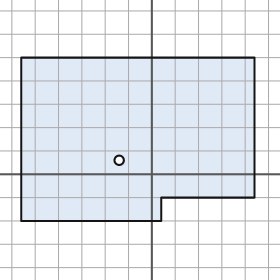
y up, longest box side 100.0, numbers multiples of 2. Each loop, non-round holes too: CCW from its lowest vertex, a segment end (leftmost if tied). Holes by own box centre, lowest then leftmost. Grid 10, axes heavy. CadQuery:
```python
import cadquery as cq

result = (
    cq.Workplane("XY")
    .moveTo(-56.0, -20.0)
    .lineTo(4.0, -20.0)
    .lineTo(4.0, -10.0)
    .lineTo(44.0, -10.0)
    .lineTo(44.0, 50.0)
    .lineTo(-56.0, 50.0)
    .close()
    .moveTo(-14.0, 6.0)
    .circle(2.0)
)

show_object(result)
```